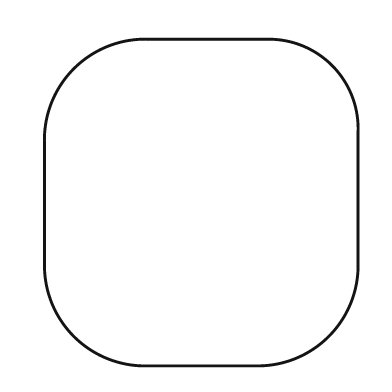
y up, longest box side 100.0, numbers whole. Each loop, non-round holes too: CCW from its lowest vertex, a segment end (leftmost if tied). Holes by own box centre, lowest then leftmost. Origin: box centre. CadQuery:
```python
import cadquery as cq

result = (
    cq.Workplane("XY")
    .moveTo(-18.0, -50.0)
    .lineTo(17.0, -50.0)
    .threePointArc((39.0, -41.0), (48.0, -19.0))
    .lineTo(48.0, 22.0)
    .threePointArc((40.0, 42.0), (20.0, 50.0))
    .lineTo(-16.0, 50.0)
    .threePointArc((-39.0, 41.0), (-48.0, 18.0))
    .lineTo(-48.0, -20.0)
    .threePointArc((-39.0, -41.0), (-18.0, -50.0))
    .close()
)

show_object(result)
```